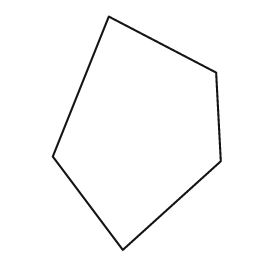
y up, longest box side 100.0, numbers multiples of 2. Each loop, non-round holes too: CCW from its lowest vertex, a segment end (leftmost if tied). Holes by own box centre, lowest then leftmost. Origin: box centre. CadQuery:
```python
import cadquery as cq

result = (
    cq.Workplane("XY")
    .moveTo(-6.0, -50.0)
    .lineTo(36.0, -12.0)
    .lineTo(34.0, 26.0)
    .lineTo(-12.0, 50.0)
    .lineTo(-36.0, -10.0)
    .close()
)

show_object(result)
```